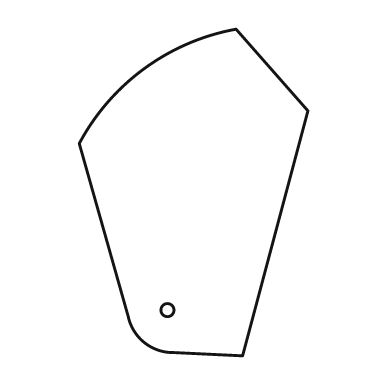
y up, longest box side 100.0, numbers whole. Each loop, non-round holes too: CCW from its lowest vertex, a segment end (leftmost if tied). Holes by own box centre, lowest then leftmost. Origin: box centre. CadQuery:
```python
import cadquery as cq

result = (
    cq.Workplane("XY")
    .moveTo(15.0, -50.0)
    .lineTo(35.0, 25.0)
    .lineTo(13.0, 50.0)
    .threePointArc((-15.0, 38.0), (-35.0, 15.0))
    .lineTo(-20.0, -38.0)
    .threePointArc((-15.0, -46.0), (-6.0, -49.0))
    .close()
    .moveTo(-8.0, -36.0)
    .circle(2.0)
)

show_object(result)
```